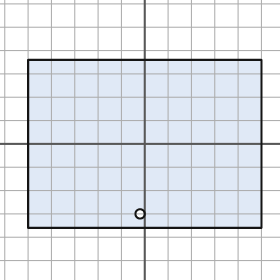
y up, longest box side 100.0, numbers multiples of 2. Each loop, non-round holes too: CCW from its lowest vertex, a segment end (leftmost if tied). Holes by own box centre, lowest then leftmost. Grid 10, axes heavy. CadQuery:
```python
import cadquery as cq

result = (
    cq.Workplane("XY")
    .moveTo(-50.0, -36.0)
    .lineTo(50.0, -36.0)
    .lineTo(50.0, 36.0)
    .lineTo(-50.0, 36.0)
    .close()
    .moveTo(-2.0, -30.0)
    .circle(2.0)
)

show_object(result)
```